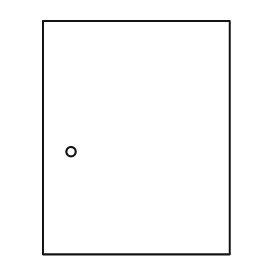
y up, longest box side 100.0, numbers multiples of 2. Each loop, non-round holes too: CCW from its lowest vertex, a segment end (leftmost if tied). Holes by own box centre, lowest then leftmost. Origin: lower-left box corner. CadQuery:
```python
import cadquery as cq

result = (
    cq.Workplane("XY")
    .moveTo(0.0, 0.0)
    .lineTo(80.0, 0.0)
    .lineTo(80.0, 100.0)
    .lineTo(0.0, 100.0)
    .close()
    .moveTo(12.0, 44.0)
    .circle(2.0)
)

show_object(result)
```